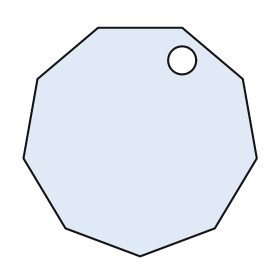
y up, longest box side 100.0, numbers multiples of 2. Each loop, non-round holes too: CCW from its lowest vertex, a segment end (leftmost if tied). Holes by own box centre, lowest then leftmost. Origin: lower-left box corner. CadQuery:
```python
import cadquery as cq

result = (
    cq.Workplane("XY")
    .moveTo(50.0, 0.0)
    .lineTo(82.0, 12.0)
    .lineTo(100.0, 42.0)
    .lineTo(94.0, 76.0)
    .lineTo(68.0, 98.0)
    .lineTo(32.0, 98.0)
    .lineTo(6.0, 76.0)
    .lineTo(0.0, 42.0)
    .lineTo(18.0, 12.0)
    .close()
    .moveTo(68.0, 84.0)
    .circle(6.0)
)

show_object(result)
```